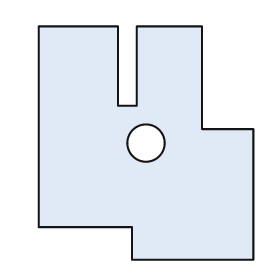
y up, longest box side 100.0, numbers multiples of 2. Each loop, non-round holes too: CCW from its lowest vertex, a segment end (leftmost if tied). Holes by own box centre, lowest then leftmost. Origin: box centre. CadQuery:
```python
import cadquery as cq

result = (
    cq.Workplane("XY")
    .moveTo(-6.0, -50.0)
    .lineTo(46.0, -50.0)
    .lineTo(46.0, 6.0)
    .lineTo(24.0, 6.0)
    .lineTo(24.0, 50.0)
    .lineTo(-4.0, 50.0)
    .lineTo(-4.0, 16.0)
    .lineTo(-12.0, 16.0)
    .lineTo(-12.0, 50.0)
    .lineTo(-46.0, 50.0)
    .lineTo(-46.0, -36.0)
    .lineTo(-6.0, -36.0)
    .close()
    .moveTo(0.0, 0.0)
    .circle(8.0)
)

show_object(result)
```